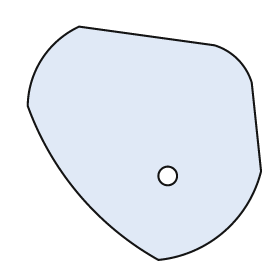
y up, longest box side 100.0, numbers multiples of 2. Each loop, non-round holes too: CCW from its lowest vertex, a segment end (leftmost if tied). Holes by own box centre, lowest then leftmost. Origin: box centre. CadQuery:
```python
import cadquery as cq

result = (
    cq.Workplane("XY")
    .moveTo(6.0, -50.0)
    .threePointArc((34.0, -38.0), (50.0, -12.0))
    .lineTo(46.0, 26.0)
    .threePointArc((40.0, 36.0), (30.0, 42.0))
    .lineTo(-28.0, 50.0)
    .threePointArc((-44.0, 36.0), (-50.0, 16.0))
    .threePointArc((-28.0, -22.0), (6.0, -50.0))
    .close()
    .moveTo(10.0, -14.0)
    .circle(4.0)
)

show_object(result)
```